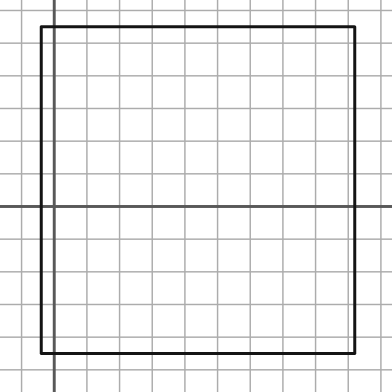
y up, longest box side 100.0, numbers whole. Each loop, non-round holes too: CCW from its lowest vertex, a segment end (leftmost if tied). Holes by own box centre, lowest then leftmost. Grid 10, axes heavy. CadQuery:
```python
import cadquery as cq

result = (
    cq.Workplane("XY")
    .moveTo(-4.0, -45.0)
    .lineTo(92.0, -45.0)
    .lineTo(92.0, 55.0)
    .lineTo(-4.0, 55.0)
    .close()
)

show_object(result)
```